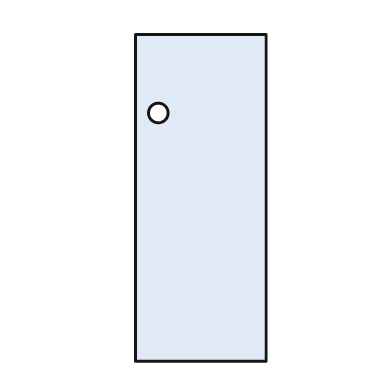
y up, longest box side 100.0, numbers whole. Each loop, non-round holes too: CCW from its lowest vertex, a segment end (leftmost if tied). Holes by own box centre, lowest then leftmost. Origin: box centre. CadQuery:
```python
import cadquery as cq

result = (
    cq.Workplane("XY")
    .moveTo(-20.0, -50.0)
    .lineTo(20.0, -50.0)
    .lineTo(20.0, 50.0)
    .lineTo(-20.0, 50.0)
    .close()
    .moveTo(-13.0, 26.0)
    .circle(3.0)
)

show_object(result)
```